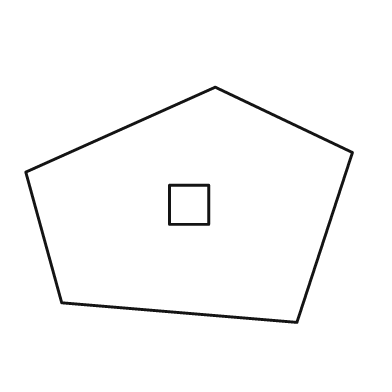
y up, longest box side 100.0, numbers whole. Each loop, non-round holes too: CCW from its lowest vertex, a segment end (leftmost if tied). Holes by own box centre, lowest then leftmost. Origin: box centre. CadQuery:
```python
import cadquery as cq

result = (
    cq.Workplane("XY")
    .moveTo(33.0, -36.0)
    .lineTo(50.0, 16.0)
    .lineTo(8.0, 36.0)
    .lineTo(-50.0, 10.0)
    .lineTo(-39.0, -30.0)
    .close()
    .moveTo(-6.0, -6.0)
    .lineTo(6.0, -6.0)
    .lineTo(6.0, 6.0)
    .lineTo(-6.0, 6.0)
    .close()
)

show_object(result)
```